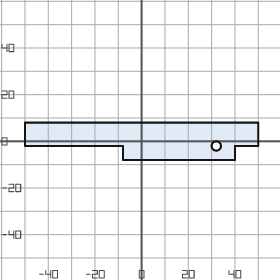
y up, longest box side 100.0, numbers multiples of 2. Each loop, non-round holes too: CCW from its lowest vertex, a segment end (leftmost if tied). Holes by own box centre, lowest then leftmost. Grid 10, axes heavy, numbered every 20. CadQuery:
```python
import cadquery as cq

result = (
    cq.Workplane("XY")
    .moveTo(-8.0, -8.0)
    .lineTo(40.0, -8.0)
    .lineTo(40.0, -2.0)
    .lineTo(50.0, -2.0)
    .lineTo(50.0, 8.0)
    .lineTo(-50.0, 8.0)
    .lineTo(-50.0, -2.0)
    .lineTo(-8.0, -2.0)
    .close()
    .moveTo(32.0, -2.0)
    .circle(2.0)
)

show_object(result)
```